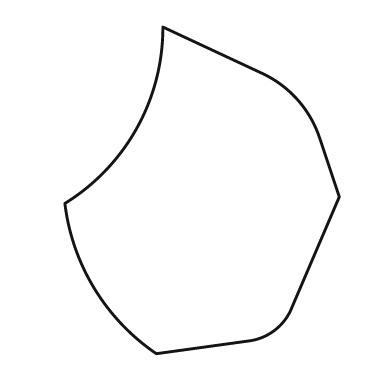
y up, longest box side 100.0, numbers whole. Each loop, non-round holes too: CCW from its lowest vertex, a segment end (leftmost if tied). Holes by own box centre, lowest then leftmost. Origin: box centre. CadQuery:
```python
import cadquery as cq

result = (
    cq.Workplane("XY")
    .moveTo(-14.0, -50.0)
    .lineTo(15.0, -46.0)
    .threePointArc((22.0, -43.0), (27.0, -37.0))
    .lineTo(42.0, -2.0)
    .lineTo(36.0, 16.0)
    .threePointArc((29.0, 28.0), (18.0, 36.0))
    .lineTo(-12.0, 50.0)
    .threePointArc((-20.0, 19.0), (-42.0, -4.0))
    .threePointArc((-33.0, -30.0), (-14.0, -50.0))
    .close()
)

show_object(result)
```